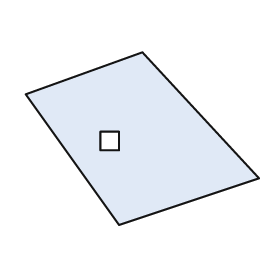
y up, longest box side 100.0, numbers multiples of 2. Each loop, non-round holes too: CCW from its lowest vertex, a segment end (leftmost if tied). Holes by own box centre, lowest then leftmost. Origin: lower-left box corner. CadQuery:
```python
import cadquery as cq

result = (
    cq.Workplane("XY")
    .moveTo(40.0, 0.0)
    .lineTo(100.0, 20.0)
    .lineTo(50.0, 74.0)
    .lineTo(0.0, 56.0)
    .close()
    .moveTo(32.0, 32.0)
    .lineTo(40.0, 32.0)
    .lineTo(40.0, 40.0)
    .lineTo(32.0, 40.0)
    .close()
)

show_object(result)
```